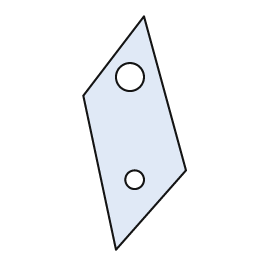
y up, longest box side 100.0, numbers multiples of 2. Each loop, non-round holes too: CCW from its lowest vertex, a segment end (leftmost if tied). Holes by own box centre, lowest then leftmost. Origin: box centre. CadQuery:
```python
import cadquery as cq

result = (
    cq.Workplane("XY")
    .moveTo(-8.0, -50.0)
    .lineTo(22.0, -16.0)
    .lineTo(4.0, 50.0)
    .lineTo(-22.0, 16.0)
    .close()
    .moveTo(0.0, -20.0)
    .circle(4.0)
    .moveTo(-2.0, 24.0)
    .circle(6.0)
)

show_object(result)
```